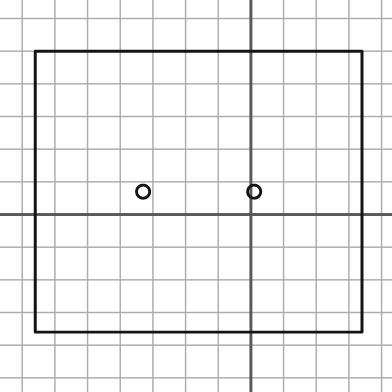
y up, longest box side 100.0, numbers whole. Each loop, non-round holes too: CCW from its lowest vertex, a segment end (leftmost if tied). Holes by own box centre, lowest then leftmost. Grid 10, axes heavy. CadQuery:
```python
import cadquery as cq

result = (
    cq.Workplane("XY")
    .moveTo(-66.0, -36.0)
    .lineTo(34.0, -36.0)
    .lineTo(34.0, 50.0)
    .lineTo(-66.0, 50.0)
    .close()
    .moveTo(-33.0, 7.0)
    .circle(2.0)
    .moveTo(1.0, 7.0)
    .circle(2.0)
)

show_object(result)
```